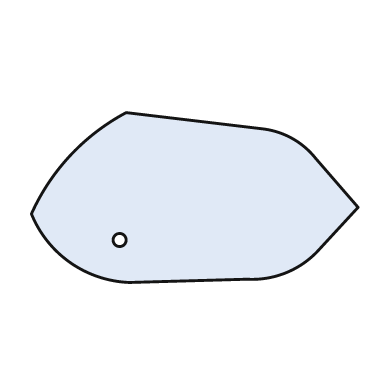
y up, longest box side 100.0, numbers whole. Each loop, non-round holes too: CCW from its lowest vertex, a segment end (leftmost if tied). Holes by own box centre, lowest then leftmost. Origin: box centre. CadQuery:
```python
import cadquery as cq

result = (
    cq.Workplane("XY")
    .moveTo(-20.0, -26.0)
    .lineTo(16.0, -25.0)
    .threePointArc((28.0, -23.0), (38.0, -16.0))
    .lineTo(50.0, -3.0)
    .lineTo(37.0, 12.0)
    .threePointArc((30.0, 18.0), (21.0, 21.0))
    .lineTo(-21.0, 26.0)
    .threePointArc((-38.0, 13.0), (-50.0, -5.0))
    .threePointArc((-38.0, -20.0), (-20.0, -26.0))
    .close()
    .moveTo(-23.0, -13.0)
    .circle(2.0)
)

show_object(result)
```